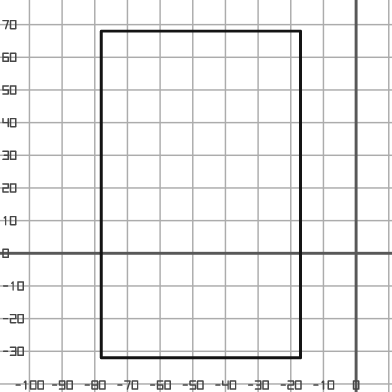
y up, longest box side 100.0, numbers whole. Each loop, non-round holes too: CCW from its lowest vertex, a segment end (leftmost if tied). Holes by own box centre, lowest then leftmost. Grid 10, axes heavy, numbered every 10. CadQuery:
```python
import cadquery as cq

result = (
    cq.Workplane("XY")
    .moveTo(-78.0, -32.0)
    .lineTo(-17.0, -32.0)
    .lineTo(-17.0, 68.0)
    .lineTo(-78.0, 68.0)
    .close()
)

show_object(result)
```